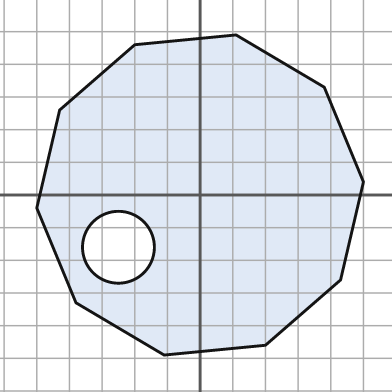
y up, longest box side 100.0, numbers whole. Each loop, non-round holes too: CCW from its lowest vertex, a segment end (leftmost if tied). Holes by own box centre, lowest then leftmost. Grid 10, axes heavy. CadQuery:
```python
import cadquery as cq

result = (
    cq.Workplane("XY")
    .moveTo(-11.0, -49.0)
    .lineTo(20.0, -46.0)
    .lineTo(43.0, -26.0)
    .lineTo(50.0, 4.0)
    .lineTo(38.0, 33.0)
    .lineTo(11.0, 49.0)
    .lineTo(-20.0, 46.0)
    .lineTo(-43.0, 26.0)
    .lineTo(-50.0, -4.0)
    .lineTo(-38.0, -33.0)
    .close()
    .moveTo(-25.0, -16.0)
    .circle(11.0)
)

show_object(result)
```